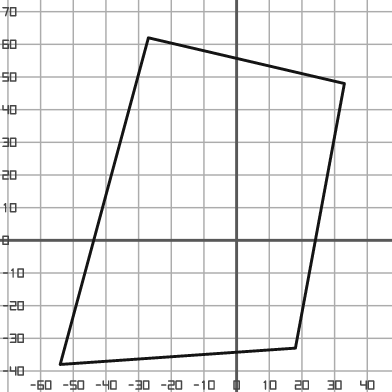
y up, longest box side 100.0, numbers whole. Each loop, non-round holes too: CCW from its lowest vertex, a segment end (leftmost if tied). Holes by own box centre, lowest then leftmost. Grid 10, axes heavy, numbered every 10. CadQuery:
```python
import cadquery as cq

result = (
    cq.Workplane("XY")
    .moveTo(-54.0, -38.0)
    .lineTo(18.0, -33.0)
    .lineTo(33.0, 48.0)
    .lineTo(-27.0, 62.0)
    .close()
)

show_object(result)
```